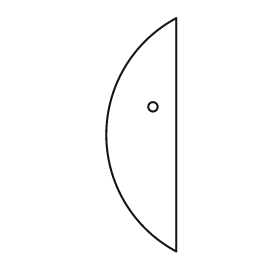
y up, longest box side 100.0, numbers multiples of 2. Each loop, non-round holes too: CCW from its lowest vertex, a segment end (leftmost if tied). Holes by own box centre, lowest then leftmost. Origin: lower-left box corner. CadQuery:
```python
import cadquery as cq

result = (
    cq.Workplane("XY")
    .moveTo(30.0, 0.0)
    .lineTo(30.0, 100.0)
    .threePointArc((0.0, 50.0), (30.0, 0.0))
    .close()
    .moveTo(20.0, 62.0)
    .circle(2.0)
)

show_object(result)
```